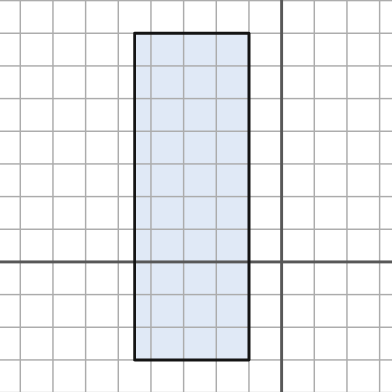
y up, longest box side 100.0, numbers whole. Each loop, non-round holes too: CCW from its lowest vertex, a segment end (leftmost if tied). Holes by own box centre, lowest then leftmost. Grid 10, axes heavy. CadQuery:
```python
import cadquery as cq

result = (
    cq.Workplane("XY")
    .moveTo(-45.0, -30.0)
    .lineTo(-10.0, -30.0)
    .lineTo(-10.0, 70.0)
    .lineTo(-45.0, 70.0)
    .close()
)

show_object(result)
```